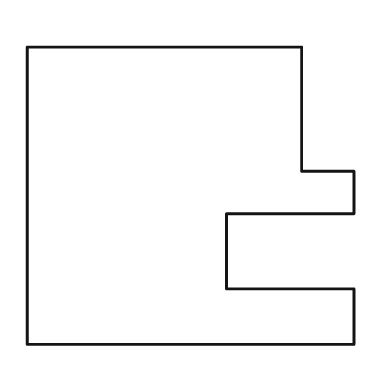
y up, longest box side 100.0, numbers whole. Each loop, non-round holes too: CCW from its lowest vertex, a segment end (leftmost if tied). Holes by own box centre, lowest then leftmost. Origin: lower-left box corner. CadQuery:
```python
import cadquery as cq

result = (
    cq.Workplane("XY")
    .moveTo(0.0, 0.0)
    .lineTo(100.0, 0.0)
    .lineTo(100.0, 17.0)
    .lineTo(61.0, 17.0)
    .lineTo(61.0, 40.0)
    .lineTo(100.0, 40.0)
    .lineTo(100.0, 53.0)
    .lineTo(84.0, 53.0)
    .lineTo(84.0, 91.0)
    .lineTo(0.0, 91.0)
    .close()
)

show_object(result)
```